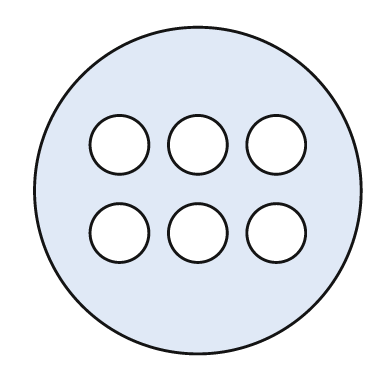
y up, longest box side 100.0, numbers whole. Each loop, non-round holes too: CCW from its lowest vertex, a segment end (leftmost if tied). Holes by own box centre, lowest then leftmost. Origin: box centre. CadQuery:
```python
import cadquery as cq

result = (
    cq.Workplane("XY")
    .moveTo(0.0, 0.0)
    .circle(50.0)
    .moveTo(-24.0, -13.0)
    .circle(9.0)
    .moveTo(0.0, -13.0)
    .circle(9.0)
    .moveTo(24.0, -13.0)
    .circle(9.0)
    .moveTo(-24.0, 14.0)
    .circle(9.0)
    .moveTo(0.0, 14.0)
    .circle(9.0)
    .moveTo(24.0, 14.0)
    .circle(9.0)
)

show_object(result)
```